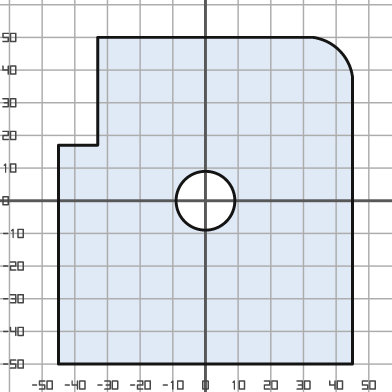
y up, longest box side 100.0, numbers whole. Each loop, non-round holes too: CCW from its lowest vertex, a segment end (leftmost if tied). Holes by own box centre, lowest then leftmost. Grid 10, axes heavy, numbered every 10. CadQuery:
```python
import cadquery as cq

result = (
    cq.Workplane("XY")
    .moveTo(-45.0, -50.0)
    .lineTo(45.0, -50.0)
    .lineTo(45.0, 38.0)
    .threePointArc((41.0, 46.0), (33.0, 50.0))
    .lineTo(-33.0, 50.0)
    .lineTo(-33.0, 17.0)
    .lineTo(-45.0, 17.0)
    .close()
    .moveTo(0.0, 0.0)
    .circle(9.0)
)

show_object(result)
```